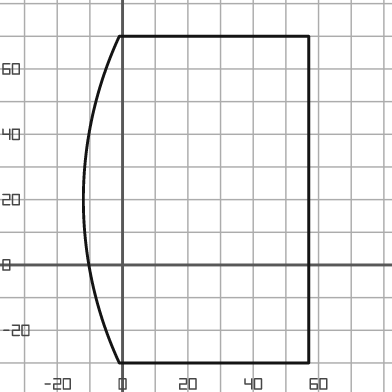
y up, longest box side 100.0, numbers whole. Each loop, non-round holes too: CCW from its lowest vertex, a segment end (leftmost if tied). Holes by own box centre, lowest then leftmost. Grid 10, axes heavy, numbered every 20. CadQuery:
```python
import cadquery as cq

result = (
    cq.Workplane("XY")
    .moveTo(-1.0, -30.0)
    .lineTo(57.0, -30.0)
    .lineTo(57.0, 70.0)
    .lineTo(-1.0, 70.0)
    .threePointArc((-12.0, 20.0), (-1.0, -30.0))
    .close()
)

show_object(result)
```